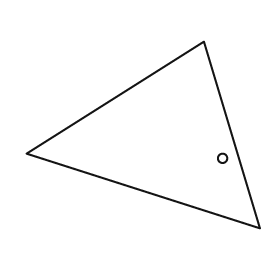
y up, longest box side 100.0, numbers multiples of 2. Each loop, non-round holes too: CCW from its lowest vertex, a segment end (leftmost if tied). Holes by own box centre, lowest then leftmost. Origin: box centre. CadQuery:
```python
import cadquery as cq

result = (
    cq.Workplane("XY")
    .moveTo(50.0, -40.0)
    .lineTo(26.0, 40.0)
    .lineTo(-50.0, -8.0)
    .close()
    .moveTo(34.0, -10.0)
    .circle(2.0)
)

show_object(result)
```